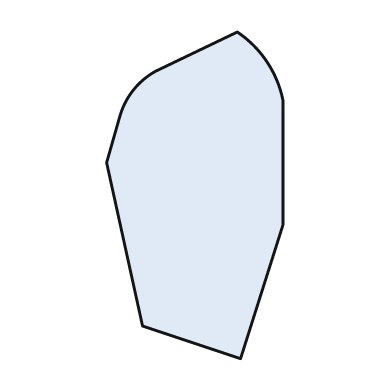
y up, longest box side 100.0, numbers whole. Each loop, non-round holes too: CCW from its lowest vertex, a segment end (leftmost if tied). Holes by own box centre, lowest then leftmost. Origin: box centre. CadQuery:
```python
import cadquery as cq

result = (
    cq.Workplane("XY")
    .moveTo(14.0, -50.0)
    .lineTo(27.0, -9.0)
    .lineTo(27.0, 29.0)
    .threePointArc((22.0, 41.0), (13.0, 50.0))
    .lineTo(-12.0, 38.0)
    .threePointArc((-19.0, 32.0), (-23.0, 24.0))
    .lineTo(-27.0, 10.0)
    .lineTo(-16.0, -40.0)
    .close()
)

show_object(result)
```